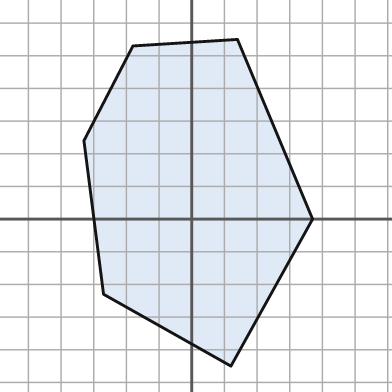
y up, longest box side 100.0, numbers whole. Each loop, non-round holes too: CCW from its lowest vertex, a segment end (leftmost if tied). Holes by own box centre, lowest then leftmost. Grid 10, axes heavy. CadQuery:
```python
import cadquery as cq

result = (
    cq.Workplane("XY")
    .moveTo(12.0, -45.0)
    .lineTo(37.0, 0.0)
    .lineTo(14.0, 55.0)
    .lineTo(-18.0, 53.0)
    .lineTo(-33.0, 24.0)
    .lineTo(-27.0, -23.0)
    .close()
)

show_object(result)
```